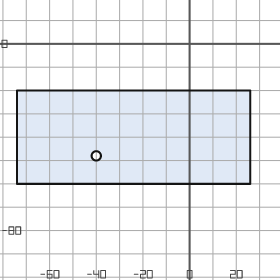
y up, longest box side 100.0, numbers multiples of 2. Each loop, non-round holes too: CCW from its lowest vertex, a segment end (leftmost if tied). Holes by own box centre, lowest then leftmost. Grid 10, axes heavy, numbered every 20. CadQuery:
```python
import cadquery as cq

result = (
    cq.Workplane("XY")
    .moveTo(-74.0, -60.0)
    .lineTo(26.0, -60.0)
    .lineTo(26.0, -20.0)
    .lineTo(-74.0, -20.0)
    .close()
    .moveTo(-40.0, -48.0)
    .circle(2.0)
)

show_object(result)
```